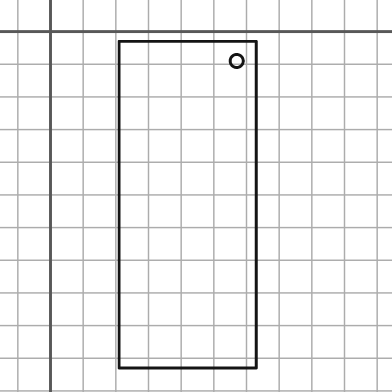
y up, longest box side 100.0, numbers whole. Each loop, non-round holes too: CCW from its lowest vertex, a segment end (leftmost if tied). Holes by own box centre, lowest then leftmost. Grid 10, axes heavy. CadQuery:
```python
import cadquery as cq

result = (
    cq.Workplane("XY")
    .moveTo(21.0, -103.0)
    .lineTo(63.0, -103.0)
    .lineTo(63.0, -3.0)
    .lineTo(21.0, -3.0)
    .close()
    .moveTo(57.0, -9.0)
    .circle(2.0)
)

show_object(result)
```